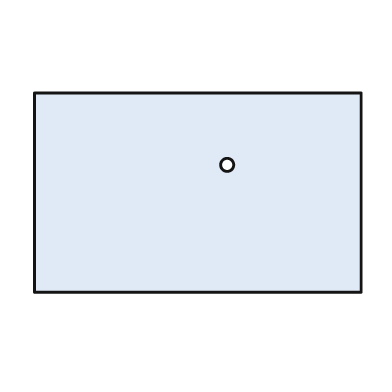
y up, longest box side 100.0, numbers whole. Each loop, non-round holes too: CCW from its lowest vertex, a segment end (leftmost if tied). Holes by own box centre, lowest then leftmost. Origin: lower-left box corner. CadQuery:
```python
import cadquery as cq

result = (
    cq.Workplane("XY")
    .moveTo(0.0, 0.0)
    .lineTo(100.0, 0.0)
    .lineTo(100.0, 61.0)
    .lineTo(0.0, 61.0)
    .close()
    .moveTo(59.0, 39.0)
    .circle(2.0)
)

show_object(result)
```